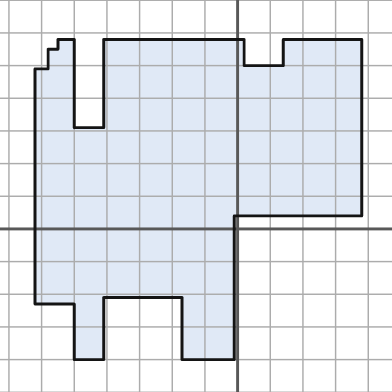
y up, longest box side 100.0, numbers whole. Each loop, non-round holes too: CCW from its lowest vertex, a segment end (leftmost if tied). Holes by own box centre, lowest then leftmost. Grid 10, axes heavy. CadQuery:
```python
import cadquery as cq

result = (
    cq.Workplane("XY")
    .moveTo(-50.0, -40.0)
    .lineTo(-41.0, -40.0)
    .lineTo(-41.0, -21.0)
    .lineTo(-17.0, -21.0)
    .lineTo(-17.0, -40.0)
    .lineTo(-1.0, -40.0)
    .lineTo(-1.0, 4.0)
    .lineTo(38.0, 4.0)
    .lineTo(38.0, 58.0)
    .lineTo(14.0, 58.0)
    .lineTo(14.0, 50.0)
    .lineTo(2.0, 50.0)
    .lineTo(2.0, 58.0)
    .lineTo(-41.0, 58.0)
    .lineTo(-41.0, 31.0)
    .lineTo(-50.0, 31.0)
    .lineTo(-50.0, 58.0)
    .lineTo(-55.0, 58.0)
    .lineTo(-55.0, 55.0)
    .lineTo(-58.0, 55.0)
    .lineTo(-58.0, 49.0)
    .lineTo(-62.0, 49.0)
    .lineTo(-62.0, -23.0)
    .lineTo(-50.0, -23.0)
    .close()
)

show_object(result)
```